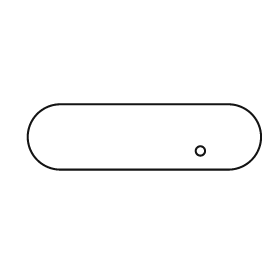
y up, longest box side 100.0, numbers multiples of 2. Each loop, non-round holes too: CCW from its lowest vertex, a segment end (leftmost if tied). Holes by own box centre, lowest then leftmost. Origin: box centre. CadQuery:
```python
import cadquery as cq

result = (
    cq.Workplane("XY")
    .moveTo(-36.0, -14.0)
    .lineTo(36.0, -14.0)
    .threePointArc((50.0, 0.0), (36.0, 14.0))
    .lineTo(-36.0, 14.0)
    .threePointArc((-50.0, 0.0), (-36.0, -14.0))
    .close()
    .moveTo(24.0, -6.0)
    .circle(2.0)
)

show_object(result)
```